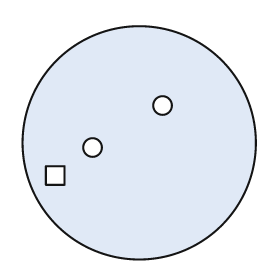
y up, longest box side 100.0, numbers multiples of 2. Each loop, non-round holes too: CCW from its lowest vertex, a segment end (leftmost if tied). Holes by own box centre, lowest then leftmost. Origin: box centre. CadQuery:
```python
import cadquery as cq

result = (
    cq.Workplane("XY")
    .moveTo(0.0, 0.0)
    .circle(50.0)
    .moveTo(-40.0, -18.0)
    .lineTo(-32.0, -18.0)
    .lineTo(-32.0, -10.0)
    .lineTo(-40.0, -10.0)
    .close()
    .moveTo(-20.0, -2.0)
    .circle(4.0)
    .moveTo(10.0, 16.0)
    .circle(4.0)
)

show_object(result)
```